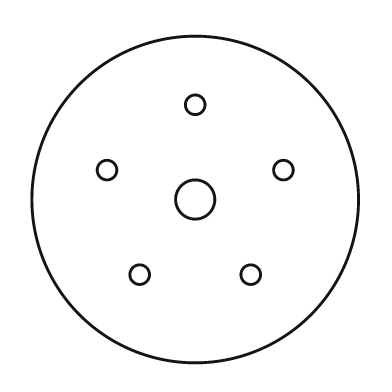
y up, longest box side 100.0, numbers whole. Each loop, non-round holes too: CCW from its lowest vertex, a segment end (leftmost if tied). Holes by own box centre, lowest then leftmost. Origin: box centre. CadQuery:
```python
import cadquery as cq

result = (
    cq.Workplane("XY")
    .moveTo(0.0, 0.0)
    .circle(50.0)
    .moveTo(-17.0, -23.0)
    .circle(3.0)
    .moveTo(17.0, -23.0)
    .circle(3.0)
    .moveTo(0.0, 0.0)
    .circle(6.0)
    .moveTo(-27.0, 9.0)
    .circle(3.0)
    .moveTo(27.0, 9.0)
    .circle(3.0)
    .moveTo(0.0, 29.0)
    .circle(3.0)
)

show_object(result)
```